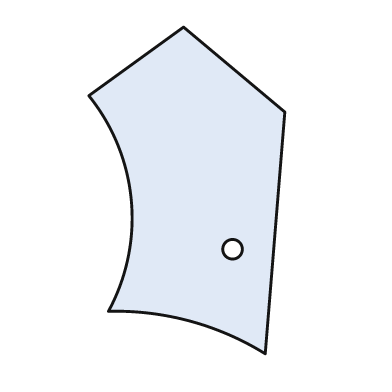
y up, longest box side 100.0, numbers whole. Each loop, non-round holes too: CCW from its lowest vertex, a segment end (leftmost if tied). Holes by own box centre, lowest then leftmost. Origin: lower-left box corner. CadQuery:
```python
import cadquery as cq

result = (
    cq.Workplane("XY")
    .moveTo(54.0, 0.0)
    .lineTo(60.0, 74.0)
    .lineTo(29.0, 100.0)
    .lineTo(0.0, 79.0)
    .threePointArc((13.0, 47.0), (6.0, 13.0))
    .threePointArc((31.0, 10.0), (54.0, 0.0))
    .close()
    .moveTo(44.0, 32.0)
    .circle(3.0)
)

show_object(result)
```